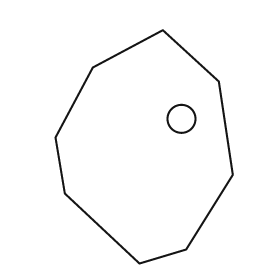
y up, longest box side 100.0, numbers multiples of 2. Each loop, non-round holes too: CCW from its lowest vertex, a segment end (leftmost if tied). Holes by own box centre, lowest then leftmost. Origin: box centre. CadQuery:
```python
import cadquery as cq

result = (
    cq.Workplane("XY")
    .moveTo(-2.0, -50.0)
    .lineTo(18.0, -44.0)
    .lineTo(38.0, -12.0)
    .lineTo(32.0, 28.0)
    .lineTo(8.0, 50.0)
    .lineTo(-22.0, 34.0)
    .lineTo(-38.0, 4.0)
    .lineTo(-34.0, -20.0)
    .close()
    .moveTo(16.0, 12.0)
    .circle(6.0)
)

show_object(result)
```